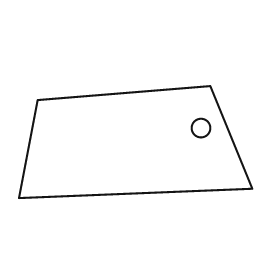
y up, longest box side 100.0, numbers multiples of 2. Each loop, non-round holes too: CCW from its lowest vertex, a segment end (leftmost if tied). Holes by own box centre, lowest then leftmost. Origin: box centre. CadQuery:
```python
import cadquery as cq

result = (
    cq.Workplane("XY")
    .moveTo(-50.0, -24.0)
    .lineTo(50.0, -20.0)
    .lineTo(32.0, 24.0)
    .lineTo(-42.0, 18.0)
    .close()
    .moveTo(28.0, 6.0)
    .circle(4.0)
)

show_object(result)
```